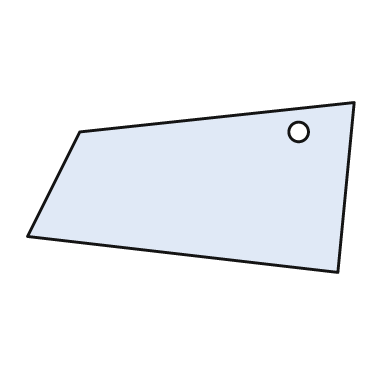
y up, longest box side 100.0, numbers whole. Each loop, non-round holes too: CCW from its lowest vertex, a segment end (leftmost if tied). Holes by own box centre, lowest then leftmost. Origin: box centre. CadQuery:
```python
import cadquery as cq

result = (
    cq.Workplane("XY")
    .moveTo(45.0, -26.0)
    .lineTo(50.0, 26.0)
    .lineTo(-34.0, 17.0)
    .lineTo(-50.0, -15.0)
    .close()
    .moveTo(33.0, 17.0)
    .circle(3.0)
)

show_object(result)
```